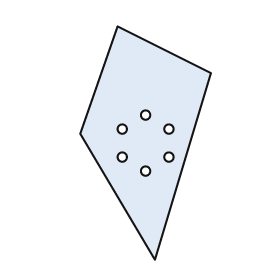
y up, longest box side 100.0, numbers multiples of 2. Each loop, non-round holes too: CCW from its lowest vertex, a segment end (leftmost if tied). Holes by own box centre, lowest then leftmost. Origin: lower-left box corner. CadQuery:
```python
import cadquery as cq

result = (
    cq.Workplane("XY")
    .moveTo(32.0, 0.0)
    .lineTo(56.0, 80.0)
    .lineTo(16.0, 100.0)
    .lineTo(0.0, 54.0)
    .close()
    .moveTo(28.0, 38.0)
    .circle(2.0)
    .moveTo(18.0, 44.0)
    .circle(2.0)
    .moveTo(38.0, 44.0)
    .circle(2.0)
    .moveTo(18.0, 56.0)
    .circle(2.0)
    .moveTo(38.0, 56.0)
    .circle(2.0)
    .moveTo(28.0, 62.0)
    .circle(2.0)
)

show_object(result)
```